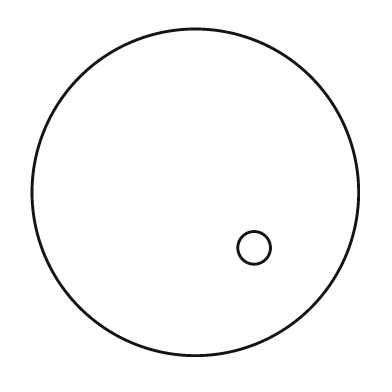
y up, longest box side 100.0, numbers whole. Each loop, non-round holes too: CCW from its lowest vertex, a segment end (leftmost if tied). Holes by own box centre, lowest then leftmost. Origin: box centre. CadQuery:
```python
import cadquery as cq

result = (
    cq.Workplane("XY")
    .moveTo(0.0, 0.0)
    .circle(50.0)
    .moveTo(18.0, -17.0)
    .circle(5.0)
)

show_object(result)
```